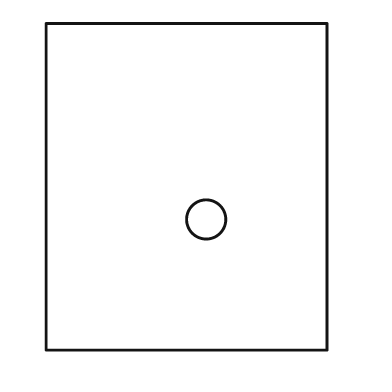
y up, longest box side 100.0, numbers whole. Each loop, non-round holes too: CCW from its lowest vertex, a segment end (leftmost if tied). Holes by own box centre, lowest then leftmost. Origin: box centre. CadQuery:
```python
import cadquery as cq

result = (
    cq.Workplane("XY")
    .moveTo(-43.0, -50.0)
    .lineTo(43.0, -50.0)
    .lineTo(43.0, 50.0)
    .lineTo(-43.0, 50.0)
    .close()
    .moveTo(6.0, -10.0)
    .circle(6.0)
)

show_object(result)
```